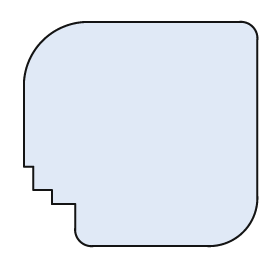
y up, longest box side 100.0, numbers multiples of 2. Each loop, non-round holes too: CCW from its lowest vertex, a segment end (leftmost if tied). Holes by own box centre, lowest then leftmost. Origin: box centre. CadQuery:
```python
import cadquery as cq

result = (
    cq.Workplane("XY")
    .moveTo(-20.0, -48.0)
    .lineTo(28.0, -48.0)
    .threePointArc((44.0, -42.0), (50.0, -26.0))
    .lineTo(50.0, 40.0)
    .threePointArc((48.0, 46.0), (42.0, 48.0))
    .lineTo(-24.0, 48.0)
    .threePointArc((-42.0, 40.0), (-50.0, 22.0))
    .lineTo(-50.0, -14.0)
    .lineTo(-46.0, -14.0)
    .lineTo(-46.0, -24.0)
    .lineTo(-38.0, -24.0)
    .lineTo(-38.0, -30.0)
    .lineTo(-28.0, -30.0)
    .lineTo(-28.0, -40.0)
    .threePointArc((-26.0, -46.0), (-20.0, -48.0))
    .close()
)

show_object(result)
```